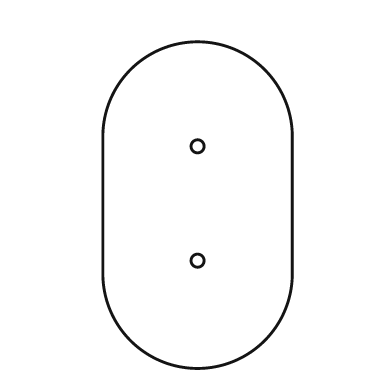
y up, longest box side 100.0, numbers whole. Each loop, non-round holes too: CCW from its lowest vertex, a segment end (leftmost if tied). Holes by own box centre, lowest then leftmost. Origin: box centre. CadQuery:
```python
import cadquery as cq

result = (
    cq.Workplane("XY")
    .moveTo(-29.0, -21.0)
    .threePointArc((0.0, -50.0), (29.0, -21.0))
    .lineTo(29.0, 21.0)
    .threePointArc((0.0, 50.0), (-29.0, 21.0))
    .close()
    .moveTo(0.0, -17.0)
    .circle(2.0)
    .moveTo(0.0, 18.0)
    .circle(2.0)
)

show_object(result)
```